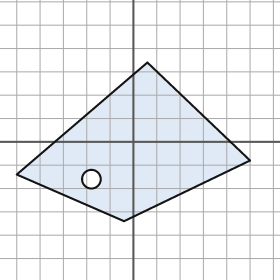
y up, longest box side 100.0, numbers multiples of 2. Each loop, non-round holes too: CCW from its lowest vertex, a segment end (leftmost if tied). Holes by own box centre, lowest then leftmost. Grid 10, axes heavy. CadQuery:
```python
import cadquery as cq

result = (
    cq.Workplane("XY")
    .moveTo(-4.0, -34.0)
    .lineTo(50.0, -8.0)
    .lineTo(6.0, 34.0)
    .lineTo(-50.0, -14.0)
    .close()
    .moveTo(-18.0, -16.0)
    .circle(4.0)
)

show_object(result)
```